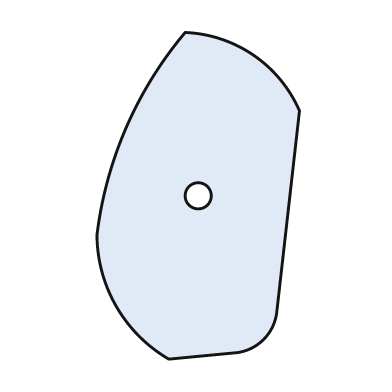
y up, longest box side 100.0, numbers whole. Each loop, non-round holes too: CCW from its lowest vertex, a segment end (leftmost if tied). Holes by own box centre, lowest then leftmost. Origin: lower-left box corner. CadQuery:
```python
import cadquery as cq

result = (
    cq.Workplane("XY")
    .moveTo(22.0, 0.0)
    .lineTo(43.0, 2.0)
    .threePointArc((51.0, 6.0), (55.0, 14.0))
    .lineTo(62.0, 76.0)
    .threePointArc((48.0, 93.0), (27.0, 100.0))
    .threePointArc((9.0, 71.0), (0.0, 38.0))
    .threePointArc((6.0, 16.0), (22.0, 0.0))
    .close()
    .moveTo(31.0, 50.0)
    .circle(4.0)
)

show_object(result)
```